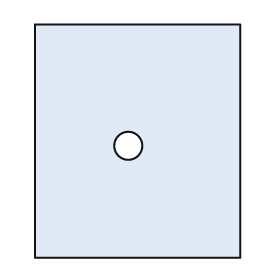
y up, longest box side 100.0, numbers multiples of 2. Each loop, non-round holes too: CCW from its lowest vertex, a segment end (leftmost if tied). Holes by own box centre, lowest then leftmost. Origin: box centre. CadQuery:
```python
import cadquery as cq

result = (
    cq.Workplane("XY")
    .moveTo(-44.0, -50.0)
    .lineTo(44.0, -50.0)
    .lineTo(44.0, 50.0)
    .lineTo(-44.0, 50.0)
    .close()
    .moveTo(-4.0, -2.0)
    .circle(6.0)
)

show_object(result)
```